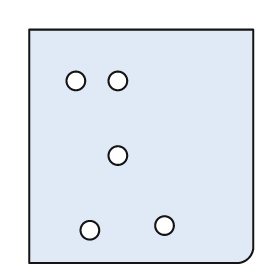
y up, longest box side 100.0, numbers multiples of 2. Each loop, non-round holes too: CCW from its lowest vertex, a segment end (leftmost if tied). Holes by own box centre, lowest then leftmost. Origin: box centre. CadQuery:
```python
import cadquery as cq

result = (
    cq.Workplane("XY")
    .moveTo(-48.0, -50.0)
    .lineTo(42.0, -50.0)
    .threePointArc((46.0, -48.0), (48.0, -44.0))
    .lineTo(48.0, 50.0)
    .lineTo(-48.0, 50.0)
    .close()
    .moveTo(-22.0, -36.0)
    .circle(4.0)
    .moveTo(10.0, -34.0)
    .circle(4.0)
    .moveTo(-10.0, -4.0)
    .circle(4.0)
    .moveTo(-28.0, 28.0)
    .circle(4.0)
    .moveTo(-10.0, 28.0)
    .circle(4.0)
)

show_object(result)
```